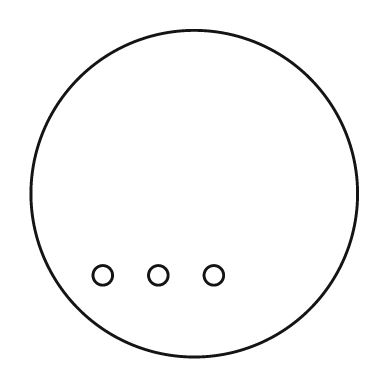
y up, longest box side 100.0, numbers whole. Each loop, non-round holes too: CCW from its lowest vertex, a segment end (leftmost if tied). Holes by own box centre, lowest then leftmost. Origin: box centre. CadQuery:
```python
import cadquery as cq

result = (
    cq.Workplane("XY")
    .moveTo(0.0, 0.0)
    .circle(50.0)
    .moveTo(-28.0, -25.0)
    .circle(3.0)
    .moveTo(-11.0, -25.0)
    .circle(3.0)
    .moveTo(6.0, -25.0)
    .circle(3.0)
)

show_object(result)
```